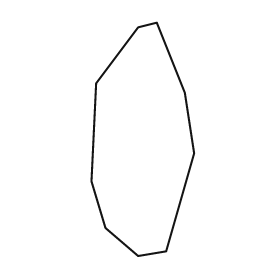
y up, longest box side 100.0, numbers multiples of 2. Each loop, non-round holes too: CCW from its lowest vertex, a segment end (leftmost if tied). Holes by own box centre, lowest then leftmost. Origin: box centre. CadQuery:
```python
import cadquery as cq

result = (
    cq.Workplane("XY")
    .moveTo(-2.0, -50.0)
    .lineTo(10.0, -48.0)
    .lineTo(22.0, -6.0)
    .lineTo(18.0, 20.0)
    .lineTo(6.0, 50.0)
    .lineTo(-2.0, 48.0)
    .lineTo(-20.0, 24.0)
    .lineTo(-22.0, -18.0)
    .lineTo(-16.0, -38.0)
    .close()
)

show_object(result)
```